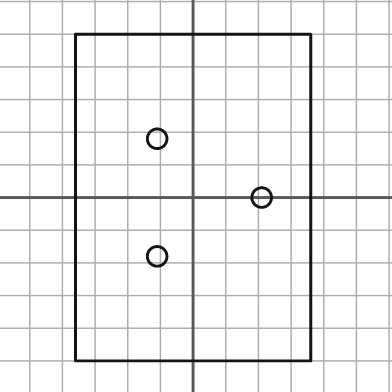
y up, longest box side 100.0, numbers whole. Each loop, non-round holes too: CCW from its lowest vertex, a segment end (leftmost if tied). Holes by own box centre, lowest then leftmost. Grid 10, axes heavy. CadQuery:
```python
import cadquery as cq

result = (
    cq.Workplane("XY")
    .moveTo(-36.0, -50.0)
    .lineTo(36.0, -50.0)
    .lineTo(36.0, 50.0)
    .lineTo(-36.0, 50.0)
    .close()
    .moveTo(-11.0, -18.0)
    .circle(3.0)
    .moveTo(21.0, 0.0)
    .circle(3.0)
    .moveTo(-11.0, 18.0)
    .circle(3.0)
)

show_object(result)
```